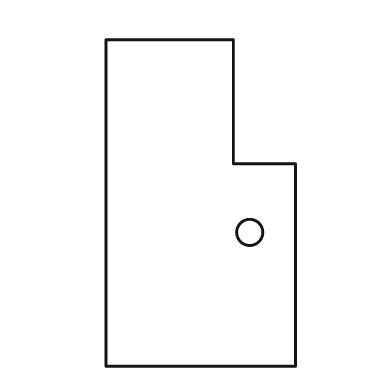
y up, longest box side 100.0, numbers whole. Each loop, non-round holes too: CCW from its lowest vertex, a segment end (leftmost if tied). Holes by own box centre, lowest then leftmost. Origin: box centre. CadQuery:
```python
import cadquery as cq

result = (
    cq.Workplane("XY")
    .moveTo(-29.0, -50.0)
    .lineTo(29.0, -50.0)
    .lineTo(29.0, 12.0)
    .lineTo(10.0, 12.0)
    .lineTo(10.0, 50.0)
    .lineTo(-29.0, 50.0)
    .close()
    .moveTo(15.0, -9.0)
    .circle(4.0)
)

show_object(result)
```